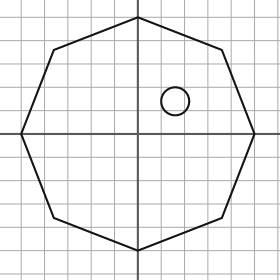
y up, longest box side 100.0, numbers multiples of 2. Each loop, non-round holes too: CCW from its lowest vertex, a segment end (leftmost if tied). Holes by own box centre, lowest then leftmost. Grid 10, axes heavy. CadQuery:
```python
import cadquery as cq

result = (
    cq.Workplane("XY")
    .moveTo(0.0, -50.0)
    .lineTo(36.0, -36.0)
    .lineTo(50.0, 0.0)
    .lineTo(36.0, 36.0)
    .lineTo(0.0, 50.0)
    .lineTo(-36.0, 36.0)
    .lineTo(-50.0, 0.0)
    .lineTo(-36.0, -36.0)
    .close()
    .moveTo(16.0, 14.0)
    .circle(6.0)
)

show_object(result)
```